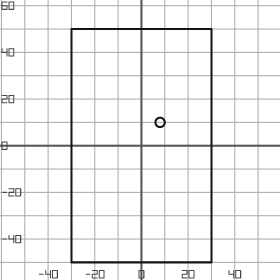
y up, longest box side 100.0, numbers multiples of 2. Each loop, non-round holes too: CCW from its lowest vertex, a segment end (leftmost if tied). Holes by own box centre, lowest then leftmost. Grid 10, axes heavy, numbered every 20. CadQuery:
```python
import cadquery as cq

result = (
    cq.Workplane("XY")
    .moveTo(-30.0, -50.0)
    .lineTo(30.0, -50.0)
    .lineTo(30.0, 50.0)
    .lineTo(-30.0, 50.0)
    .close()
    .moveTo(8.0, 10.0)
    .circle(2.0)
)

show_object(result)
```